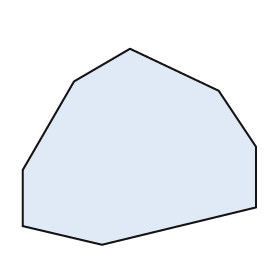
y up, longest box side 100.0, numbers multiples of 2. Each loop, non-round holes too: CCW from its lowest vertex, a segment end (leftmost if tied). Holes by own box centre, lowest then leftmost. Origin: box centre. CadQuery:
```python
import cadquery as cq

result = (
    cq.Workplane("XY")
    .moveTo(-16.0, -42.0)
    .lineTo(50.0, -26.0)
    .lineTo(50.0, 0.0)
    .lineTo(34.0, 24.0)
    .lineTo(-4.0, 42.0)
    .lineTo(-28.0, 28.0)
    .lineTo(-50.0, -10.0)
    .lineTo(-50.0, -34.0)
    .close()
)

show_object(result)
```